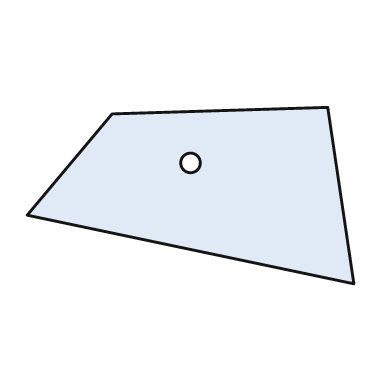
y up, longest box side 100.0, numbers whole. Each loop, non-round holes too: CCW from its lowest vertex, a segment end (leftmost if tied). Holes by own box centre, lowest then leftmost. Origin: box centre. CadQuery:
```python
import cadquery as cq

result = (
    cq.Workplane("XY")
    .moveTo(50.0, -27.0)
    .lineTo(42.0, 27.0)
    .lineTo(-24.0, 25.0)
    .lineTo(-50.0, -6.0)
    .close()
    .moveTo(0.0, 10.0)
    .circle(3.0)
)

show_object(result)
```